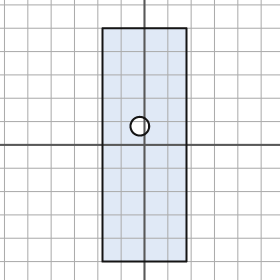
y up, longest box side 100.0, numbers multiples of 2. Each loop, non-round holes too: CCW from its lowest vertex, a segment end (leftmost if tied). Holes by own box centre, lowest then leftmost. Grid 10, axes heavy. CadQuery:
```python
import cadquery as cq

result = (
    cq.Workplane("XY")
    .moveTo(-18.0, -50.0)
    .lineTo(18.0, -50.0)
    .lineTo(18.0, 50.0)
    .lineTo(-18.0, 50.0)
    .close()
    .moveTo(-2.0, 8.0)
    .circle(4.0)
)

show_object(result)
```